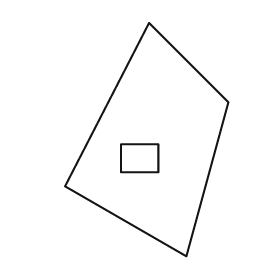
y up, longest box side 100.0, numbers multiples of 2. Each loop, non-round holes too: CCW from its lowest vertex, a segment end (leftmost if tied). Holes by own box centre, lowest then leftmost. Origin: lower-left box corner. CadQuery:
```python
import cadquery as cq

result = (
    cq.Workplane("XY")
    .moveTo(52.0, 0.0)
    .lineTo(70.0, 66.0)
    .lineTo(36.0, 100.0)
    .lineTo(0.0, 30.0)
    .close()
    .moveTo(24.0, 36.0)
    .lineTo(40.0, 36.0)
    .lineTo(40.0, 48.0)
    .lineTo(24.0, 48.0)
    .close()
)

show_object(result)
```